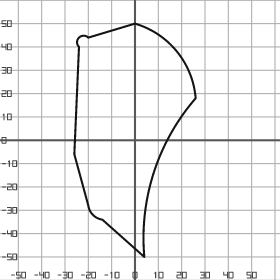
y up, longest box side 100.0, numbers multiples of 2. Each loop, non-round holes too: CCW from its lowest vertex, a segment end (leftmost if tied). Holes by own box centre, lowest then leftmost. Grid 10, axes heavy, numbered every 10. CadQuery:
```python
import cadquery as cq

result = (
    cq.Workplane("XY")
    .moveTo(4.0, -50.0)
    .threePointArc((8.0, -14.0), (26.0, 18.0))
    .threePointArc((18.0, 38.0), (0.0, 50.0))
    .lineTo(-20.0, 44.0)
    .threePointArc((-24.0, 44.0), (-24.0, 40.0))
    .lineTo(-26.0, -6.0)
    .lineTo(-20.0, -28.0)
    .threePointArc((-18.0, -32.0), (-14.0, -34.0))
    .close()
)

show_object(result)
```